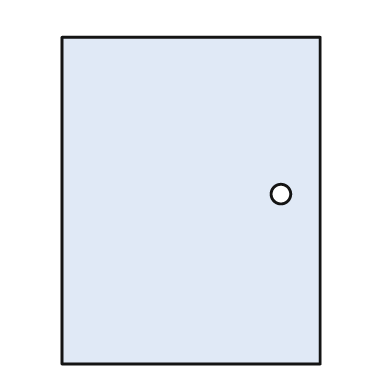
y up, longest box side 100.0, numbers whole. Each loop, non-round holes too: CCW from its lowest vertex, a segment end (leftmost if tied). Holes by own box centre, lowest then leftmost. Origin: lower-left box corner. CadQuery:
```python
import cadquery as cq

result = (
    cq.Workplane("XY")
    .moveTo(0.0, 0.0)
    .lineTo(79.0, 0.0)
    .lineTo(79.0, 100.0)
    .lineTo(0.0, 100.0)
    .close()
    .moveTo(67.0, 52.0)
    .circle(3.0)
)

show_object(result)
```